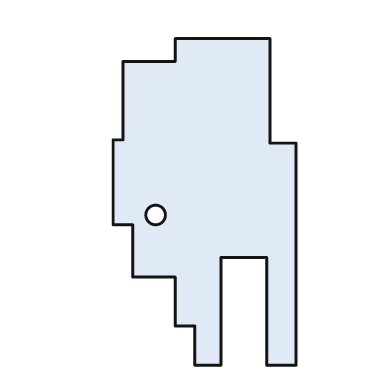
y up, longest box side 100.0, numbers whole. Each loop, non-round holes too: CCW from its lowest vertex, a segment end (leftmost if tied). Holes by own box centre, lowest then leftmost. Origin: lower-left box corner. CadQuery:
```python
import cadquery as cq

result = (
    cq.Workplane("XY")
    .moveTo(25.0, 0.0)
    .lineTo(33.0, 0.0)
    .lineTo(33.0, 33.0)
    .lineTo(47.0, 33.0)
    .lineTo(47.0, 0.0)
    .lineTo(56.0, 0.0)
    .lineTo(56.0, 68.0)
    .lineTo(48.0, 68.0)
    .lineTo(48.0, 100.0)
    .lineTo(19.0, 100.0)
    .lineTo(19.0, 93.0)
    .lineTo(3.0, 93.0)
    .lineTo(3.0, 69.0)
    .lineTo(0.0, 69.0)
    .lineTo(0.0, 43.0)
    .lineTo(6.0, 43.0)
    .lineTo(6.0, 27.0)
    .lineTo(19.0, 27.0)
    .lineTo(19.0, 12.0)
    .lineTo(25.0, 12.0)
    .close()
    .moveTo(13.0, 46.0)
    .circle(3.0)
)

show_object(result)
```